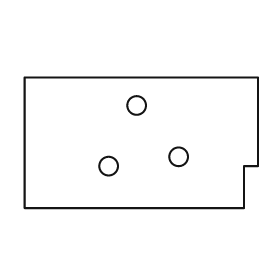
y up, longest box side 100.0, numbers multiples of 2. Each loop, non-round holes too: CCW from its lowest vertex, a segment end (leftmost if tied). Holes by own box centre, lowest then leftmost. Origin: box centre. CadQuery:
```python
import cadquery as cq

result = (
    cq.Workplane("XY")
    .moveTo(-50.0, -28.0)
    .lineTo(44.0, -28.0)
    .lineTo(44.0, -10.0)
    .lineTo(50.0, -10.0)
    .lineTo(50.0, 28.0)
    .lineTo(-50.0, 28.0)
    .close()
    .moveTo(-14.0, -10.0)
    .circle(4.0)
    .moveTo(16.0, -6.0)
    .circle(4.0)
    .moveTo(-2.0, 16.0)
    .circle(4.0)
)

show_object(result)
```